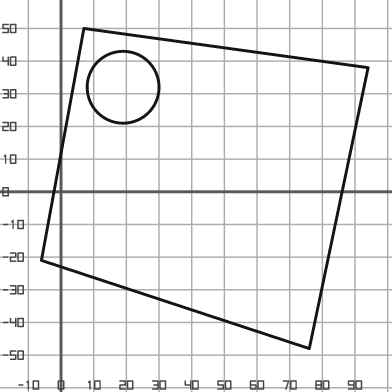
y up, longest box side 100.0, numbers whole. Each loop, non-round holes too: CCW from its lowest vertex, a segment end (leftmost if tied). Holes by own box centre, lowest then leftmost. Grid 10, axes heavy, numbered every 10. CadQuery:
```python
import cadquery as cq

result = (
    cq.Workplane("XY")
    .moveTo(76.0, -48.0)
    .lineTo(94.0, 38.0)
    .lineTo(7.0, 50.0)
    .lineTo(-6.0, -21.0)
    .close()
    .moveTo(19.0, 32.0)
    .circle(11.0)
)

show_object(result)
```